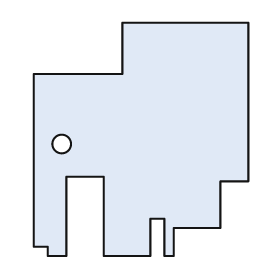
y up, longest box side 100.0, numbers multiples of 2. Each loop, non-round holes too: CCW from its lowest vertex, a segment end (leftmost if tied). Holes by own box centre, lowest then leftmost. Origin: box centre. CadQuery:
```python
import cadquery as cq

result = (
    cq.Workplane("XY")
    .moveTo(-40.0, -50.0)
    .lineTo(-32.0, -50.0)
    .lineTo(-32.0, -16.0)
    .lineTo(-16.0, -16.0)
    .lineTo(-16.0, -50.0)
    .lineTo(4.0, -50.0)
    .lineTo(4.0, -34.0)
    .lineTo(10.0, -34.0)
    .lineTo(10.0, -50.0)
    .lineTo(14.0, -50.0)
    .lineTo(14.0, -38.0)
    .lineTo(34.0, -38.0)
    .lineTo(34.0, -18.0)
    .lineTo(46.0, -18.0)
    .lineTo(46.0, 50.0)
    .lineTo(-8.0, 50.0)
    .lineTo(-8.0, 28.0)
    .lineTo(-46.0, 28.0)
    .lineTo(-46.0, -46.0)
    .lineTo(-40.0, -46.0)
    .close()
    .moveTo(-34.0, -2.0)
    .circle(4.0)
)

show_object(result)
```